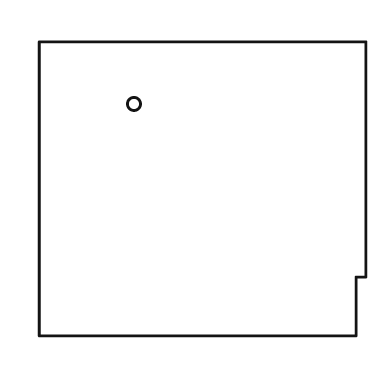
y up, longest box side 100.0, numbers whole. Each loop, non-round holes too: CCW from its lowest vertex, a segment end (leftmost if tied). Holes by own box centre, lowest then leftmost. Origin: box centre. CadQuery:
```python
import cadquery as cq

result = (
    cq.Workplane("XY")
    .moveTo(-50.0, -45.0)
    .lineTo(47.0, -45.0)
    .lineTo(47.0, -27.0)
    .lineTo(50.0, -27.0)
    .lineTo(50.0, 45.0)
    .lineTo(-50.0, 45.0)
    .close()
    .moveTo(-21.0, 26.0)
    .circle(2.0)
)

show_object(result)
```